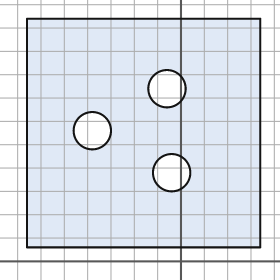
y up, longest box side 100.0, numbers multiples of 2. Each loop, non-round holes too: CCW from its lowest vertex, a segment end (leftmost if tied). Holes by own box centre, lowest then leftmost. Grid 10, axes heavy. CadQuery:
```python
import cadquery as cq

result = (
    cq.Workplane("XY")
    .moveTo(-66.0, 6.0)
    .lineTo(34.0, 6.0)
    .lineTo(34.0, 104.0)
    .lineTo(-66.0, 104.0)
    .close()
    .moveTo(-4.0, 38.0)
    .circle(8.0)
    .moveTo(-38.0, 56.0)
    .circle(8.0)
    .moveTo(-6.0, 74.0)
    .circle(8.0)
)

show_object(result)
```